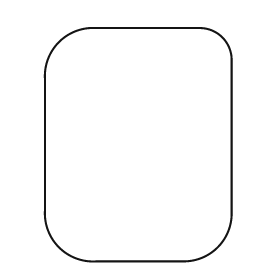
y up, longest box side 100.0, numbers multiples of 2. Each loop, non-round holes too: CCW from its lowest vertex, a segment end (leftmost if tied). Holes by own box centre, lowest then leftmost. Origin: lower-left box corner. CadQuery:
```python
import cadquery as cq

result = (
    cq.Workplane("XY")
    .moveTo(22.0, 0.0)
    .lineTo(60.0, 0.0)
    .threePointArc((74.0, 6.0), (80.0, 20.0))
    .lineTo(80.0, 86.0)
    .threePointArc((76.0, 96.0), (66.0, 100.0))
    .lineTo(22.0, 100.0)
    .threePointArc((6.0, 94.0), (0.0, 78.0))
    .lineTo(0.0, 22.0)
    .threePointArc((6.0, 6.0), (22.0, 0.0))
    .close()
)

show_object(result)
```